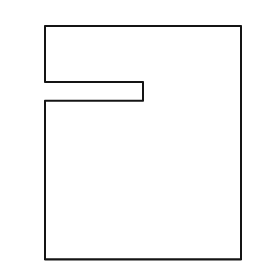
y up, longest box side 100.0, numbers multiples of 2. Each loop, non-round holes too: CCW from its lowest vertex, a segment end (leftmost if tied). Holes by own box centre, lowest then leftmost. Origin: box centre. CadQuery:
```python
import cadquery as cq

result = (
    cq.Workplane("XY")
    .moveTo(-42.0, -50.0)
    .lineTo(42.0, -50.0)
    .lineTo(42.0, 50.0)
    .lineTo(-42.0, 50.0)
    .lineTo(-42.0, 26.0)
    .lineTo(0.0, 26.0)
    .lineTo(0.0, 18.0)
    .lineTo(-42.0, 18.0)
    .close()
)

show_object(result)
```